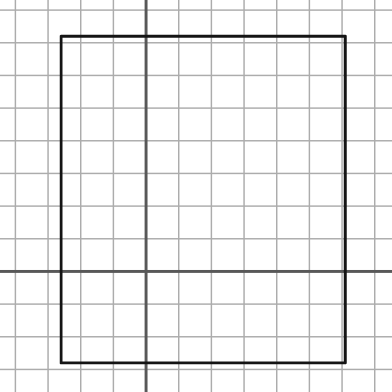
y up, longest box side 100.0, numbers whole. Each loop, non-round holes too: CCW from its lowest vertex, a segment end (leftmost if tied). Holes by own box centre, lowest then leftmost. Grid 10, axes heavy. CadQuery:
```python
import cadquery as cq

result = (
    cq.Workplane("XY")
    .moveTo(-26.0, -28.0)
    .lineTo(61.0, -28.0)
    .lineTo(61.0, 72.0)
    .lineTo(-26.0, 72.0)
    .close()
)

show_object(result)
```